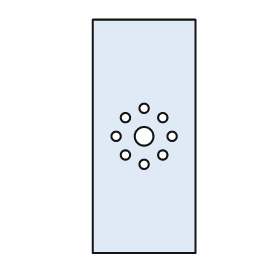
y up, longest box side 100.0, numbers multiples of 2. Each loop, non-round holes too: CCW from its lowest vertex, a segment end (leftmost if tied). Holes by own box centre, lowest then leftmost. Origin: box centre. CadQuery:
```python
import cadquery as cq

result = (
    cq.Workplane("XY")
    .moveTo(-22.0, -50.0)
    .lineTo(22.0, -50.0)
    .lineTo(22.0, 50.0)
    .lineTo(-22.0, 50.0)
    .close()
    .moveTo(0.0, -12.0)
    .circle(2.0)
    .moveTo(-8.0, -8.0)
    .circle(2.0)
    .moveTo(8.0, -8.0)
    .circle(2.0)
    .moveTo(-12.0, 0.0)
    .circle(2.0)
    .moveTo(0.0, 0.0)
    .circle(4.0)
    .moveTo(12.0, 0.0)
    .circle(2.0)
    .moveTo(-8.0, 8.0)
    .circle(2.0)
    .moveTo(8.0, 8.0)
    .circle(2.0)
    .moveTo(0.0, 12.0)
    .circle(2.0)
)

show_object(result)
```